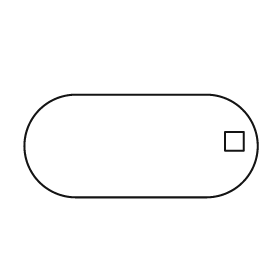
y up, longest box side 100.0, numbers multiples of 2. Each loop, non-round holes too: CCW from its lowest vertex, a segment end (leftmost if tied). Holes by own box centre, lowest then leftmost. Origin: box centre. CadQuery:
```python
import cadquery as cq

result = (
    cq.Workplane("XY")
    .moveTo(-28.0, -22.0)
    .lineTo(28.0, -22.0)
    .threePointArc((50.0, 0.0), (28.0, 22.0))
    .lineTo(-28.0, 22.0)
    .threePointArc((-50.0, 0.0), (-28.0, -22.0))
    .close()
    .moveTo(36.0, -2.0)
    .lineTo(44.0, -2.0)
    .lineTo(44.0, 6.0)
    .lineTo(36.0, 6.0)
    .close()
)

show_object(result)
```